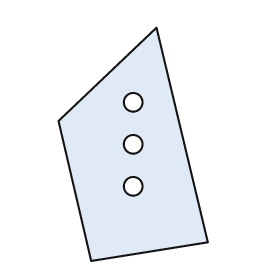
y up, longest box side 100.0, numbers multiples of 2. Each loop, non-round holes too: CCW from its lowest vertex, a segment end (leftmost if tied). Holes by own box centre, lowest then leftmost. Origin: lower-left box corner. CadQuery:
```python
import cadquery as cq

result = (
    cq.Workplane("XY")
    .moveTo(14.0, 0.0)
    .lineTo(64.0, 8.0)
    .lineTo(42.0, 100.0)
    .lineTo(0.0, 60.0)
    .close()
    .moveTo(32.0, 32.0)
    .circle(4.0)
    .moveTo(32.0, 50.0)
    .circle(4.0)
    .moveTo(32.0, 68.0)
    .circle(4.0)
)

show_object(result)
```